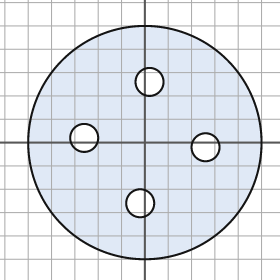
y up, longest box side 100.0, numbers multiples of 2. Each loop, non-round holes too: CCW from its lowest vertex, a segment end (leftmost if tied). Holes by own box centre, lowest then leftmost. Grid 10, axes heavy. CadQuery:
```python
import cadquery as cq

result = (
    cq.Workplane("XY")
    .moveTo(0.0, 0.0)
    .circle(50.0)
    .moveTo(-2.0, -26.0)
    .circle(6.0)
    .moveTo(26.0, -2.0)
    .circle(6.0)
    .moveTo(-26.0, 2.0)
    .circle(6.0)
    .moveTo(2.0, 26.0)
    .circle(6.0)
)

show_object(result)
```